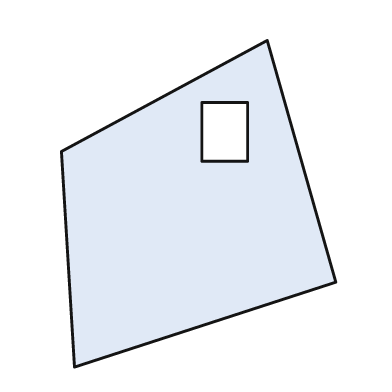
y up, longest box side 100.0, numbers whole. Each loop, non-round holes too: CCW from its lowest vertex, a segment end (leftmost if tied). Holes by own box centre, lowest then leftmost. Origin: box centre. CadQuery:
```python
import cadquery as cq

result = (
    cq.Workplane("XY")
    .moveTo(-38.0, -50.0)
    .lineTo(42.0, -24.0)
    .lineTo(21.0, 50.0)
    .lineTo(-42.0, 16.0)
    .close()
    .moveTo(1.0, 13.0)
    .lineTo(15.0, 13.0)
    .lineTo(15.0, 31.0)
    .lineTo(1.0, 31.0)
    .close()
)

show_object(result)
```